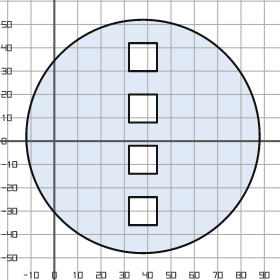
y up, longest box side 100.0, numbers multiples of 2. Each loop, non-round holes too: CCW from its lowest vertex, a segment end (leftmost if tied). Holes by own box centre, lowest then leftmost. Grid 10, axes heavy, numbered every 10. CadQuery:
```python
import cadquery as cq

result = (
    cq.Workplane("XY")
    .moveTo(38.0, 2.0)
    .circle(50.0)
    .moveTo(32.0, -36.0)
    .lineTo(44.0, -36.0)
    .lineTo(44.0, -24.0)
    .lineTo(32.0, -24.0)
    .close()
    .moveTo(32.0, -14.0)
    .lineTo(44.0, -14.0)
    .lineTo(44.0, -2.0)
    .lineTo(32.0, -2.0)
    .close()
    .moveTo(32.0, 8.0)
    .lineTo(44.0, 8.0)
    .lineTo(44.0, 20.0)
    .lineTo(32.0, 20.0)
    .close()
    .moveTo(32.0, 30.0)
    .lineTo(44.0, 30.0)
    .lineTo(44.0, 42.0)
    .lineTo(32.0, 42.0)
    .close()
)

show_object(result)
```